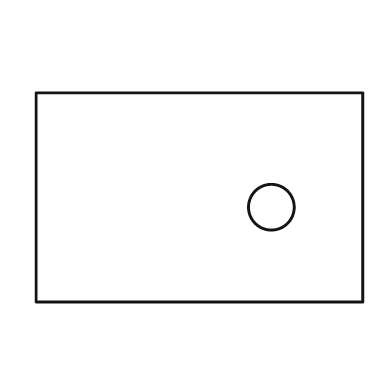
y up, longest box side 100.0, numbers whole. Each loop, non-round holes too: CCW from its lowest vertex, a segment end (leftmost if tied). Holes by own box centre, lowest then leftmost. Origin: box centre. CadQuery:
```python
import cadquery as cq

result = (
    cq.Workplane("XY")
    .moveTo(-50.0, -32.0)
    .lineTo(50.0, -32.0)
    .lineTo(50.0, 32.0)
    .lineTo(-50.0, 32.0)
    .close()
    .moveTo(22.0, -3.0)
    .circle(7.0)
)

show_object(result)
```